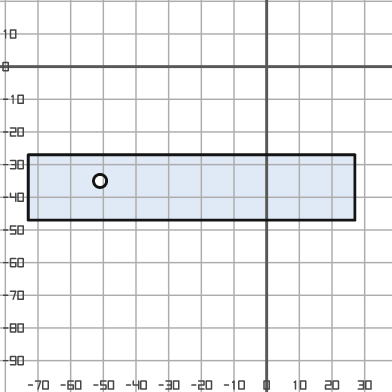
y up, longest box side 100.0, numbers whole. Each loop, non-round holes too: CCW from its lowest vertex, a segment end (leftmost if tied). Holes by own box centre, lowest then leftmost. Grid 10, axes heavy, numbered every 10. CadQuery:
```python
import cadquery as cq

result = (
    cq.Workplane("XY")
    .moveTo(-73.0, -47.0)
    .lineTo(27.0, -47.0)
    .lineTo(27.0, -27.0)
    .lineTo(-73.0, -27.0)
    .close()
    .moveTo(-51.0, -35.0)
    .circle(2.0)
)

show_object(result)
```